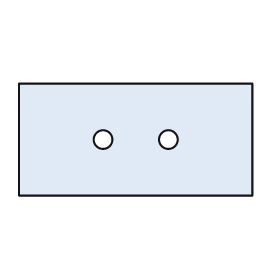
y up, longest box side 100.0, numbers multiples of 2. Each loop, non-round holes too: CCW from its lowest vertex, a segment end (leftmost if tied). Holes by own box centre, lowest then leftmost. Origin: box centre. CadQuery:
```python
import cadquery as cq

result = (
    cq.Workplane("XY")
    .moveTo(-50.0, -24.0)
    .lineTo(50.0, -24.0)
    .lineTo(50.0, 24.0)
    .lineTo(-50.0, 24.0)
    .close()
    .moveTo(-14.0, 0.0)
    .circle(4.0)
    .moveTo(14.0, 0.0)
    .circle(4.0)
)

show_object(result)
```